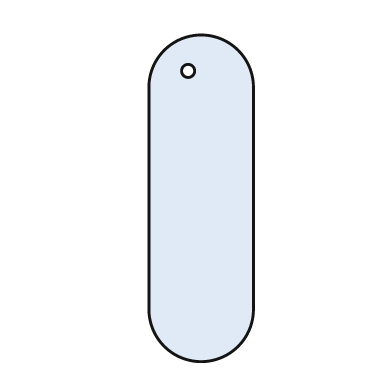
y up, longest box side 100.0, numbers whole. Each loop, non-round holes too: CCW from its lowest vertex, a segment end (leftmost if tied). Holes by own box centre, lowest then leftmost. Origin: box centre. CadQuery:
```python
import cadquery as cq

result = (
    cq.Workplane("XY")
    .moveTo(-16.0, -34.0)
    .threePointArc((0.0, -50.0), (16.0, -34.0))
    .lineTo(16.0, 34.0)
    .threePointArc((0.0, 50.0), (-16.0, 34.0))
    .close()
    .moveTo(-4.0, 39.0)
    .circle(2.0)
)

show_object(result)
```